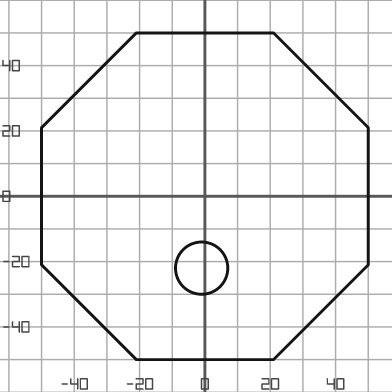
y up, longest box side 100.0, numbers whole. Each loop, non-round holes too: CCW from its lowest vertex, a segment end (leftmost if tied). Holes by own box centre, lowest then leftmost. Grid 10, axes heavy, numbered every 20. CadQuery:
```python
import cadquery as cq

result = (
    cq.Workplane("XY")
    .moveTo(-21.0, -50.0)
    .lineTo(21.0, -50.0)
    .lineTo(50.0, -21.0)
    .lineTo(50.0, 21.0)
    .lineTo(21.0, 50.0)
    .lineTo(-21.0, 50.0)
    .lineTo(-50.0, 21.0)
    .lineTo(-50.0, -21.0)
    .close()
    .moveTo(-1.0, -22.0)
    .circle(8.0)
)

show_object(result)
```